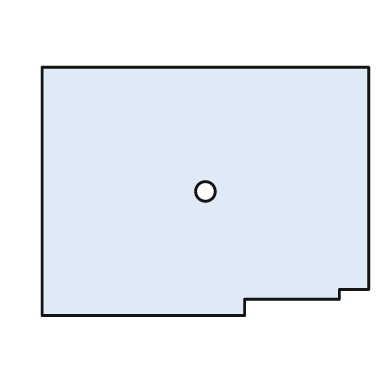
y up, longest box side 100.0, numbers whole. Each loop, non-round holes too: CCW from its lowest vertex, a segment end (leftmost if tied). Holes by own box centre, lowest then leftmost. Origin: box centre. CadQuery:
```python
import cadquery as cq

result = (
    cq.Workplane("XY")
    .moveTo(-50.0, -38.0)
    .lineTo(12.0, -38.0)
    .lineTo(12.0, -33.0)
    .lineTo(41.0, -33.0)
    .lineTo(41.0, -30.0)
    .lineTo(50.0, -30.0)
    .lineTo(50.0, 38.0)
    .lineTo(-50.0, 38.0)
    .close()
    .moveTo(0.0, 0.0)
    .circle(3.0)
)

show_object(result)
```